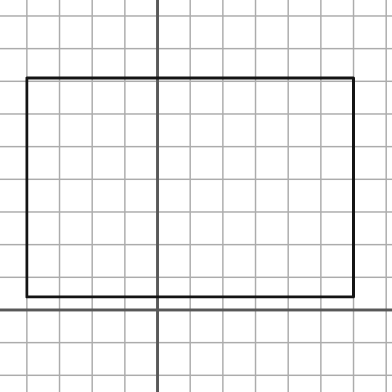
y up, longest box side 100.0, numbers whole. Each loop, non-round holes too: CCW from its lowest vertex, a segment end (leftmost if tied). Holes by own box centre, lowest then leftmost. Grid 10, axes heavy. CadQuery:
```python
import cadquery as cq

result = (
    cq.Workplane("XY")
    .moveTo(-40.0, 4.0)
    .lineTo(60.0, 4.0)
    .lineTo(60.0, 71.0)
    .lineTo(-40.0, 71.0)
    .close()
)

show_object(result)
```